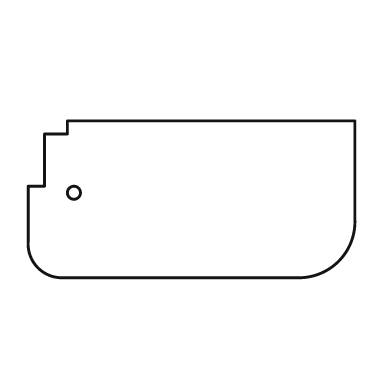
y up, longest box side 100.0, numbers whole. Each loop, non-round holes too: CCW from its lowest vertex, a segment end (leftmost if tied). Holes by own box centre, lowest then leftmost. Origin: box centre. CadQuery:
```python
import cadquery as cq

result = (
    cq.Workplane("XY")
    .moveTo(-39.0, -24.0)
    .lineTo(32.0, -24.0)
    .threePointArc((45.0, -19.0), (50.0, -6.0))
    .lineTo(50.0, 24.0)
    .lineTo(-38.0, 24.0)
    .lineTo(-38.0, 20.0)
    .lineTo(-45.0, 20.0)
    .lineTo(-45.0, 4.0)
    .lineTo(-50.0, 4.0)
    .lineTo(-50.0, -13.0)
    .threePointArc((-47.0, -21.0), (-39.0, -24.0))
    .close()
    .moveTo(-36.0, 2.0)
    .circle(2.0)
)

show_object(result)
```